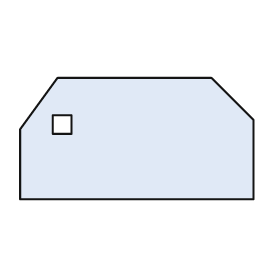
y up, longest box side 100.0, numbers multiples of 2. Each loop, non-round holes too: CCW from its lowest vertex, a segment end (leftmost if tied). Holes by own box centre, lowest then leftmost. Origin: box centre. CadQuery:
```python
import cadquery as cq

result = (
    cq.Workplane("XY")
    .moveTo(-50.0, -26.0)
    .lineTo(50.0, -26.0)
    .lineTo(50.0, 8.0)
    .lineTo(32.0, 26.0)
    .lineTo(-34.0, 26.0)
    .lineTo(-50.0, 4.0)
    .close()
    .moveTo(-36.0, 2.0)
    .lineTo(-28.0, 2.0)
    .lineTo(-28.0, 10.0)
    .lineTo(-36.0, 10.0)
    .close()
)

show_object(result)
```